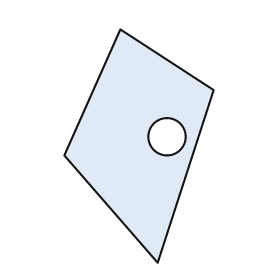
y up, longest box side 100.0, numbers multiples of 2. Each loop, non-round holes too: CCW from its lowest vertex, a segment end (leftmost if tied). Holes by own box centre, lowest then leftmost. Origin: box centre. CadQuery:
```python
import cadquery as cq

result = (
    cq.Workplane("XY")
    .moveTo(8.0, -50.0)
    .lineTo(32.0, 24.0)
    .lineTo(-8.0, 50.0)
    .lineTo(-32.0, -4.0)
    .close()
    .moveTo(12.0, 4.0)
    .circle(8.0)
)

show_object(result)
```